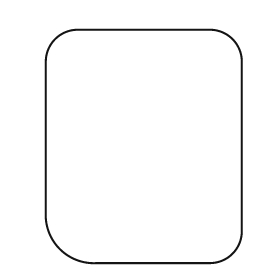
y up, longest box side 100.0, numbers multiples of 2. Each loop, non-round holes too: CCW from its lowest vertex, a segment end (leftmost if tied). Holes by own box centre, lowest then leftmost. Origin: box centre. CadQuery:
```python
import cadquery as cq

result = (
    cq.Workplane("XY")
    .moveTo(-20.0, -50.0)
    .lineTo(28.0, -50.0)
    .threePointArc((38.0, -46.0), (42.0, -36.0))
    .lineTo(42.0, 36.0)
    .threePointArc((38.0, 46.0), (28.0, 50.0))
    .lineTo(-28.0, 50.0)
    .threePointArc((-38.0, 46.0), (-42.0, 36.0))
    .lineTo(-42.0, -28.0)
    .threePointArc((-36.0, -44.0), (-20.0, -50.0))
    .close()
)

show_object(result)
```